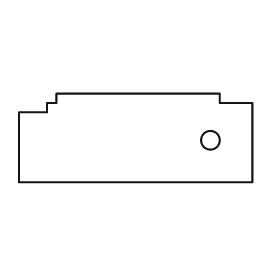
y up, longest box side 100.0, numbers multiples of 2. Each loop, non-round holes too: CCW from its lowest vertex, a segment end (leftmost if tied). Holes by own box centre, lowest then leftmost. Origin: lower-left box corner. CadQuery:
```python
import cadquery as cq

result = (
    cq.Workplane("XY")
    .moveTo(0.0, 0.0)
    .lineTo(100.0, 0.0)
    .lineTo(100.0, 34.0)
    .lineTo(86.0, 34.0)
    .lineTo(86.0, 38.0)
    .lineTo(16.0, 38.0)
    .lineTo(16.0, 34.0)
    .lineTo(12.0, 34.0)
    .lineTo(12.0, 30.0)
    .lineTo(0.0, 30.0)
    .close()
    .moveTo(82.0, 18.0)
    .circle(4.0)
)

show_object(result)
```